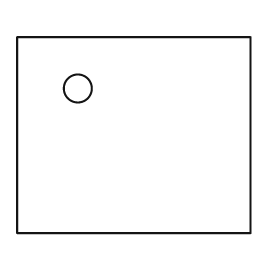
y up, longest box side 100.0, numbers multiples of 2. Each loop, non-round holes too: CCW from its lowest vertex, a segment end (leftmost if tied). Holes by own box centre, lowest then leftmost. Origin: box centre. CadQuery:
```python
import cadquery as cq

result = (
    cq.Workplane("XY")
    .moveTo(-50.0, -42.0)
    .lineTo(50.0, -42.0)
    .lineTo(50.0, 42.0)
    .lineTo(-50.0, 42.0)
    .close()
    .moveTo(-24.0, 20.0)
    .circle(6.0)
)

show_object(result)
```